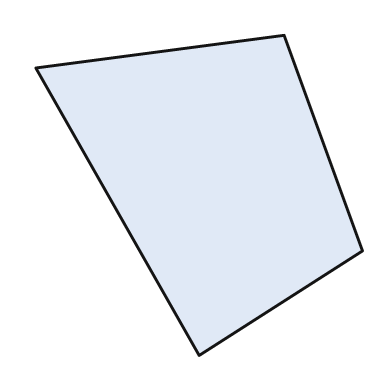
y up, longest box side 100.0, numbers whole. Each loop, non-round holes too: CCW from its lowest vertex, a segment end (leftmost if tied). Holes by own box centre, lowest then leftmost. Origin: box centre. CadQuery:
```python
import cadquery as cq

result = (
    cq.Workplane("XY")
    .moveTo(0.0, -49.0)
    .lineTo(50.0, -17.0)
    .lineTo(26.0, 49.0)
    .lineTo(-50.0, 39.0)
    .close()
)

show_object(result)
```